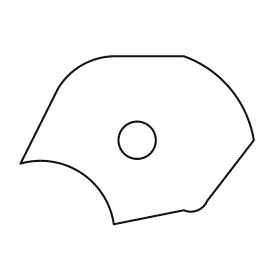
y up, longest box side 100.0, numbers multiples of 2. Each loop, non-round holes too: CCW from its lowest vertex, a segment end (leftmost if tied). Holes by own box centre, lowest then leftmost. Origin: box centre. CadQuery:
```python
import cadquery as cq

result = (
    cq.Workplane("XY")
    .moveTo(-10.0, -36.0)
    .lineTo(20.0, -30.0)
    .threePointArc((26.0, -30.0), (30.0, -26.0))
    .lineTo(50.0, 0.0)
    .threePointArc((40.0, 22.0), (20.0, 36.0))
    .lineTo(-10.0, 36.0)
    .threePointArc((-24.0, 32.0), (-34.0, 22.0))
    .lineTo(-50.0, -10.0)
    .threePointArc((-24.0, -14.0), (-10.0, -36.0))
    .close()
    .moveTo(0.0, 0.0)
    .circle(8.0)
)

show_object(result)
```